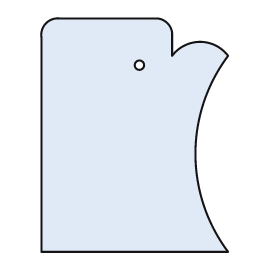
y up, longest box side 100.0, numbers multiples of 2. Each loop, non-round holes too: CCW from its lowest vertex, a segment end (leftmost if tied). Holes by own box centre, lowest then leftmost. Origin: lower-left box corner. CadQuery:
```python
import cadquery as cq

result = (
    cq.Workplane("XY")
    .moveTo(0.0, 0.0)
    .lineTo(80.0, 0.0)
    .threePointArc((66.0, 42.0), (80.0, 84.0))
    .threePointArc((68.0, 90.0), (56.0, 84.0))
    .lineTo(56.0, 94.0)
    .threePointArc((54.0, 98.0), (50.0, 100.0))
    .lineTo(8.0, 100.0)
    .threePointArc((2.0, 98.0), (0.0, 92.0))
    .close()
    .moveTo(42.0, 80.0)
    .circle(2.0)
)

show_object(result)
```